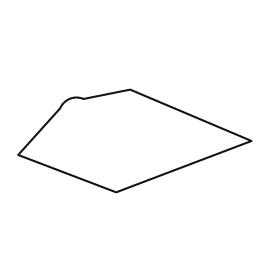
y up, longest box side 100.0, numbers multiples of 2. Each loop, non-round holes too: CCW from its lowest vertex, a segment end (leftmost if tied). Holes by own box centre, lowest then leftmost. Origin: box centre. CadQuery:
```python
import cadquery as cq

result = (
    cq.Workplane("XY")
    .moveTo(-8.0, -22.0)
    .lineTo(50.0, 0.0)
    .lineTo(-2.0, 22.0)
    .lineTo(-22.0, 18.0)
    .threePointArc((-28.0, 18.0), (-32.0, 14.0))
    .lineTo(-50.0, -6.0)
    .close()
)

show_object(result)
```